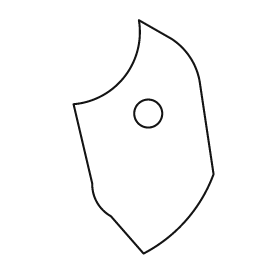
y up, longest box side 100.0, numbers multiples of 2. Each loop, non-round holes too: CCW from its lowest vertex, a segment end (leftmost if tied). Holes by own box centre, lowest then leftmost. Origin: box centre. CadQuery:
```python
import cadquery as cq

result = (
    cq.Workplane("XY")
    .moveTo(0.0, -50.0)
    .threePointArc((18.0, -36.0), (30.0, -16.0))
    .lineTo(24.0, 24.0)
    .threePointArc((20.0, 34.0), (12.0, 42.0))
    .lineTo(-2.0, 50.0)
    .threePointArc((-8.0, 26.0), (-30.0, 14.0))
    .lineTo(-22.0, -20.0)
    .threePointArc((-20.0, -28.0), (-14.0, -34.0))
    .close()
    .moveTo(2.0, 10.0)
    .circle(6.0)
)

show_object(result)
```